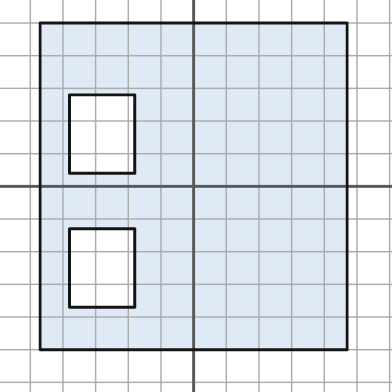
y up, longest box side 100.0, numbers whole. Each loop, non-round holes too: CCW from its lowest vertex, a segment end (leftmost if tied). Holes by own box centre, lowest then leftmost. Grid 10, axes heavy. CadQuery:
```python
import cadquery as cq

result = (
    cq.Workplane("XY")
    .moveTo(-47.0, -50.0)
    .lineTo(47.0, -50.0)
    .lineTo(47.0, 50.0)
    .lineTo(-47.0, 50.0)
    .close()
    .moveTo(-38.0, -37.0)
    .lineTo(-18.0, -37.0)
    .lineTo(-18.0, -13.0)
    .lineTo(-38.0, -13.0)
    .close()
    .moveTo(-38.0, 4.0)
    .lineTo(-18.0, 4.0)
    .lineTo(-18.0, 28.0)
    .lineTo(-38.0, 28.0)
    .close()
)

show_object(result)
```